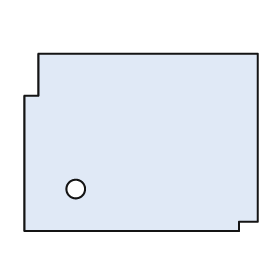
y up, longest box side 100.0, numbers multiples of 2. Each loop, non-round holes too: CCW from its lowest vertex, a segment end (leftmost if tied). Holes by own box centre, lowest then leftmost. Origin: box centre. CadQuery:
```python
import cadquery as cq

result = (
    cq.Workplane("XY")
    .moveTo(-50.0, -38.0)
    .lineTo(42.0, -38.0)
    .lineTo(42.0, -34.0)
    .lineTo(50.0, -34.0)
    .lineTo(50.0, 38.0)
    .lineTo(-44.0, 38.0)
    .lineTo(-44.0, 20.0)
    .lineTo(-50.0, 20.0)
    .close()
    .moveTo(-28.0, -20.0)
    .circle(4.0)
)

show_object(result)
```